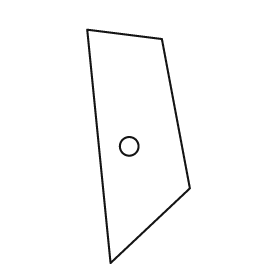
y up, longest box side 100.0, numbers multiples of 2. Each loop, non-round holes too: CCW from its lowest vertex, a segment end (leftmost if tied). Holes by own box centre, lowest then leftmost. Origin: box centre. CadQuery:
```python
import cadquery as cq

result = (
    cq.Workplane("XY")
    .moveTo(-12.0, -50.0)
    .lineTo(22.0, -18.0)
    .lineTo(10.0, 46.0)
    .lineTo(-22.0, 50.0)
    .close()
    .moveTo(-4.0, 0.0)
    .circle(4.0)
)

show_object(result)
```